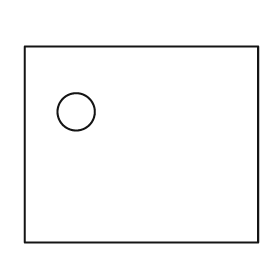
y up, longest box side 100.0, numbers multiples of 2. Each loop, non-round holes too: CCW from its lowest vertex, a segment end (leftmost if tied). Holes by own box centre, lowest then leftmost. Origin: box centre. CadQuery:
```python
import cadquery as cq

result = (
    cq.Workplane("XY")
    .moveTo(-50.0, -42.0)
    .lineTo(50.0, -42.0)
    .lineTo(50.0, 42.0)
    .lineTo(-50.0, 42.0)
    .close()
    .moveTo(-28.0, 14.0)
    .circle(8.0)
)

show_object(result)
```